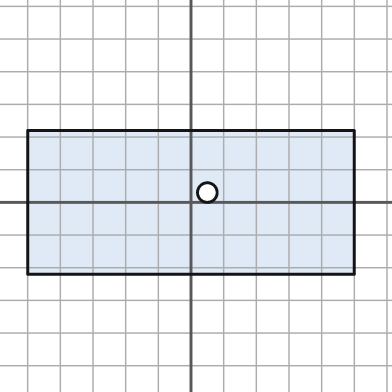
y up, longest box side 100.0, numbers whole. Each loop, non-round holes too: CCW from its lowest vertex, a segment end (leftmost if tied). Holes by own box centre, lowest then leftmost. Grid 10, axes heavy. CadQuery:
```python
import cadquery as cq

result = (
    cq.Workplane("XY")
    .moveTo(-50.0, -22.0)
    .lineTo(50.0, -22.0)
    .lineTo(50.0, 22.0)
    .lineTo(-50.0, 22.0)
    .close()
    .moveTo(5.0, 3.0)
    .circle(3.0)
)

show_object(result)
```